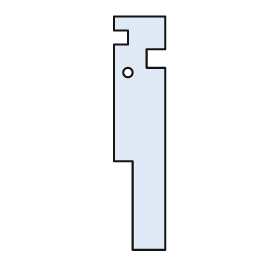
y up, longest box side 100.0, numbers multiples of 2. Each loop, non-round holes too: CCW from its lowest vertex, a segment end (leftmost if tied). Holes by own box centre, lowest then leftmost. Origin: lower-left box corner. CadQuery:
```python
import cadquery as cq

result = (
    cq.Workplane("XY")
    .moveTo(8.0, 0.0)
    .lineTo(22.0, 0.0)
    .lineTo(22.0, 78.0)
    .lineTo(14.0, 78.0)
    .lineTo(14.0, 86.0)
    .lineTo(22.0, 86.0)
    .lineTo(22.0, 100.0)
    .lineTo(0.0, 100.0)
    .lineTo(0.0, 94.0)
    .lineTo(6.0, 94.0)
    .lineTo(6.0, 88.0)
    .lineTo(0.0, 88.0)
    .lineTo(0.0, 38.0)
    .lineTo(8.0, 38.0)
    .close()
    .moveTo(6.0, 76.0)
    .circle(2.0)
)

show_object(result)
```